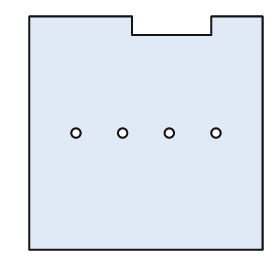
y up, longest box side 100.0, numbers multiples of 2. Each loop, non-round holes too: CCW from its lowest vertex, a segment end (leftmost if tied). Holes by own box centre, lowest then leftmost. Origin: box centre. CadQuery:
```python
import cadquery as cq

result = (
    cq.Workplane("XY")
    .moveTo(-50.0, -50.0)
    .lineTo(50.0, -50.0)
    .lineTo(50.0, 50.0)
    .lineTo(28.0, 50.0)
    .lineTo(28.0, 42.0)
    .lineTo(-6.0, 42.0)
    .lineTo(-6.0, 50.0)
    .lineTo(-50.0, 50.0)
    .close()
    .moveTo(-30.0, 0.0)
    .circle(2.0)
    .moveTo(-10.0, 0.0)
    .circle(2.0)
    .moveTo(10.0, 0.0)
    .circle(2.0)
    .moveTo(30.0, 0.0)
    .circle(2.0)
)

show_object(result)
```